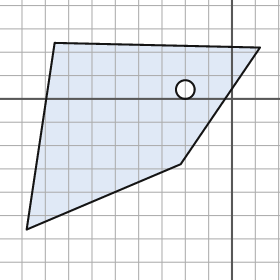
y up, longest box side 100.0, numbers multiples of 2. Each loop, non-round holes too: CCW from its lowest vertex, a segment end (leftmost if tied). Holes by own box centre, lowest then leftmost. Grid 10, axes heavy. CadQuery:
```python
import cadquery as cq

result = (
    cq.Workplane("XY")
    .moveTo(-88.0, -56.0)
    .lineTo(-22.0, -28.0)
    .lineTo(12.0, 22.0)
    .lineTo(-76.0, 24.0)
    .close()
    .moveTo(-20.0, 4.0)
    .circle(4.0)
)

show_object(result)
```